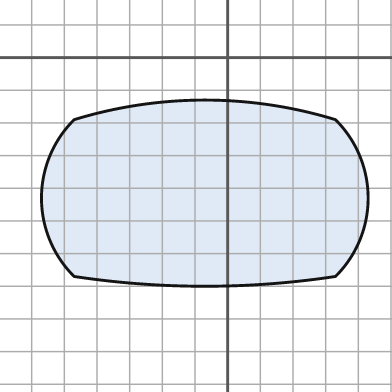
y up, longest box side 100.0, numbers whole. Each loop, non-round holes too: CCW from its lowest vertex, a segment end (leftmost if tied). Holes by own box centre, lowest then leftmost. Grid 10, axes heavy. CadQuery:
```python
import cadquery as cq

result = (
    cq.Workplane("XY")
    .moveTo(-47.0, -67.0)
    .threePointArc((-7.0, -70.0), (33.0, -67.0))
    .threePointArc((43.0, -43.0), (33.0, -19.0))
    .threePointArc((-7.0, -13.0), (-47.0, -19.0))
    .threePointArc((-57.0, -43.0), (-47.0, -67.0))
    .close()
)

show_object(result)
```